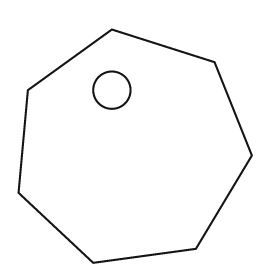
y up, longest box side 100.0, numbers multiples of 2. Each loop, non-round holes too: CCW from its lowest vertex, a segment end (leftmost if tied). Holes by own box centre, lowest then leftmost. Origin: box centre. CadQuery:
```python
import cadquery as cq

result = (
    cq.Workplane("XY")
    .moveTo(-18.0, -50.0)
    .lineTo(26.0, -44.0)
    .lineTo(50.0, -4.0)
    .lineTo(34.0, 36.0)
    .lineTo(-10.0, 50.0)
    .lineTo(-46.0, 24.0)
    .lineTo(-50.0, -20.0)
    .close()
    .moveTo(-10.0, 24.0)
    .circle(8.0)
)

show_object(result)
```